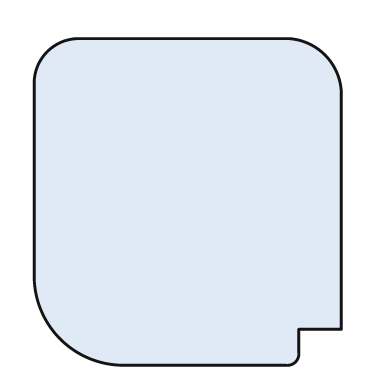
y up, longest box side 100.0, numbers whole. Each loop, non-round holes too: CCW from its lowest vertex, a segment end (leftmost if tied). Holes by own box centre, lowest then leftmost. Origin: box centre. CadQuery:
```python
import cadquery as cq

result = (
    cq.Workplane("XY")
    .moveTo(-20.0, -50.0)
    .lineTo(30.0, -50.0)
    .threePointArc((33.0, -49.0), (34.0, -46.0))
    .lineTo(34.0, -39.0)
    .lineTo(47.0, -39.0)
    .lineTo(47.0, 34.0)
    .threePointArc((42.0, 45.0), (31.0, 50.0))
    .lineTo(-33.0, 50.0)
    .threePointArc((-43.0, 46.0), (-47.0, 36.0))
    .lineTo(-47.0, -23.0)
    .threePointArc((-39.0, -42.0), (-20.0, -50.0))
    .close()
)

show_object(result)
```